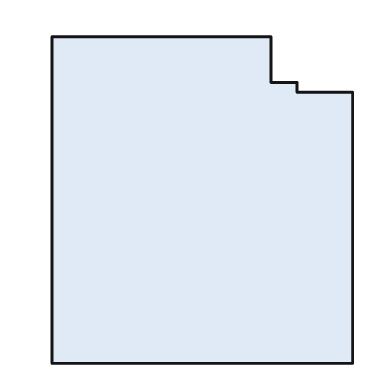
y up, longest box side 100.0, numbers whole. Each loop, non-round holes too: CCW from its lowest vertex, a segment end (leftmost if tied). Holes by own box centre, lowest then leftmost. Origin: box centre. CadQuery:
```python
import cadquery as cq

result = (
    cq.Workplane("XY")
    .moveTo(-46.0, -50.0)
    .lineTo(46.0, -50.0)
    .lineTo(46.0, 33.0)
    .lineTo(29.0, 33.0)
    .lineTo(29.0, 36.0)
    .lineTo(21.0, 36.0)
    .lineTo(21.0, 50.0)
    .lineTo(-46.0, 50.0)
    .close()
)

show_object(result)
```